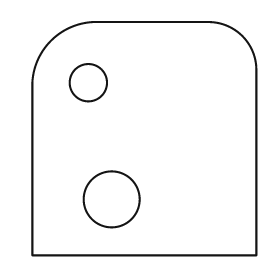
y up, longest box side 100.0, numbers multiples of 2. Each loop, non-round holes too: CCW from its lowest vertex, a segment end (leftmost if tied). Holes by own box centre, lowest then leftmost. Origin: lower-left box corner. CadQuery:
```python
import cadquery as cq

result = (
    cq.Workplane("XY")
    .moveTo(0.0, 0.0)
    .lineTo(96.0, 0.0)
    .lineTo(96.0, 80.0)
    .threePointArc((90.0, 94.0), (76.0, 100.0))
    .lineTo(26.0, 100.0)
    .threePointArc((8.0, 92.0), (0.0, 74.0))
    .close()
    .moveTo(34.0, 24.0)
    .circle(12.0)
    .moveTo(24.0, 74.0)
    .circle(8.0)
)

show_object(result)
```